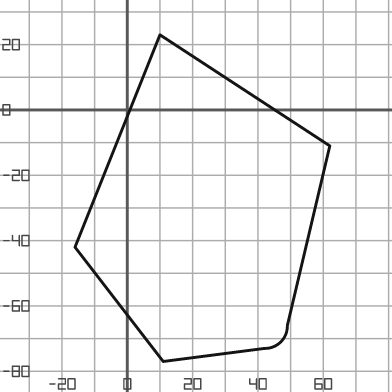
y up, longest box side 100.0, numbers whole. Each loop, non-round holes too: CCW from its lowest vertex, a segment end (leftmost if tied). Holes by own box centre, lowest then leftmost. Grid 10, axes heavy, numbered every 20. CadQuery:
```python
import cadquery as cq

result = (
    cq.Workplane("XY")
    .moveTo(11.0, -77.0)
    .lineTo(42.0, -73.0)
    .threePointArc((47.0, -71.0), (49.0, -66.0))
    .lineTo(62.0, -11.0)
    .lineTo(10.0, 23.0)
    .lineTo(-16.0, -42.0)
    .close()
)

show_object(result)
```